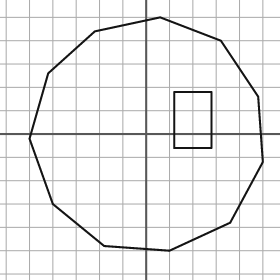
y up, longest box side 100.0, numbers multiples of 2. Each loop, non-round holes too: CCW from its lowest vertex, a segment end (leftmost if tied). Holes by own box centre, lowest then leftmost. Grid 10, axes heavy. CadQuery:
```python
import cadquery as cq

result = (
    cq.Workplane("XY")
    .moveTo(10.0, -50.0)
    .lineTo(36.0, -38.0)
    .lineTo(50.0, -12.0)
    .lineTo(48.0, 16.0)
    .lineTo(32.0, 40.0)
    .lineTo(6.0, 50.0)
    .lineTo(-22.0, 44.0)
    .lineTo(-42.0, 26.0)
    .lineTo(-50.0, -2.0)
    .lineTo(-40.0, -30.0)
    .lineTo(-18.0, -48.0)
    .close()
    .moveTo(12.0, -6.0)
    .lineTo(28.0, -6.0)
    .lineTo(28.0, 18.0)
    .lineTo(12.0, 18.0)
    .close()
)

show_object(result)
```